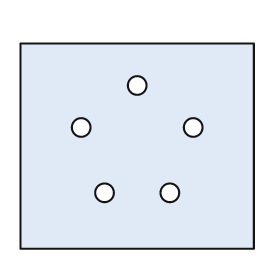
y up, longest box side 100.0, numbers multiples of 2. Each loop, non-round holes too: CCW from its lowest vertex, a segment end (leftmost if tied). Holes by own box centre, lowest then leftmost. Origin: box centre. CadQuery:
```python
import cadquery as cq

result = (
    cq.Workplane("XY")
    .moveTo(-50.0, -44.0)
    .lineTo(50.0, -44.0)
    .lineTo(50.0, 44.0)
    .lineTo(-50.0, 44.0)
    .close()
    .moveTo(-14.0, -20.0)
    .circle(4.0)
    .moveTo(14.0, -20.0)
    .circle(4.0)
    .moveTo(-24.0, 8.0)
    .circle(4.0)
    .moveTo(24.0, 8.0)
    .circle(4.0)
    .moveTo(0.0, 26.0)
    .circle(4.0)
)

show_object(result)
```